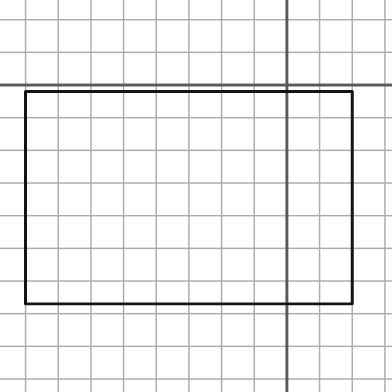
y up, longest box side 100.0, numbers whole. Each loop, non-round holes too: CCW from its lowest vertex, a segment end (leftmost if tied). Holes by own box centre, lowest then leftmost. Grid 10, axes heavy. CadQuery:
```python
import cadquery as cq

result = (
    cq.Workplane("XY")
    .moveTo(-80.0, -67.0)
    .lineTo(20.0, -67.0)
    .lineTo(20.0, -2.0)
    .lineTo(-80.0, -2.0)
    .close()
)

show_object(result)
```